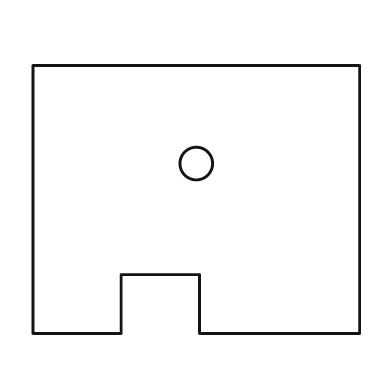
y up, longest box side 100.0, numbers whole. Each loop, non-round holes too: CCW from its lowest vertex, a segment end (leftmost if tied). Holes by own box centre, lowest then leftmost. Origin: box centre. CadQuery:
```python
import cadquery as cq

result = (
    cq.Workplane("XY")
    .moveTo(-50.0, -41.0)
    .lineTo(-23.0, -41.0)
    .lineTo(-23.0, -23.0)
    .lineTo(1.0, -23.0)
    .lineTo(1.0, -41.0)
    .lineTo(50.0, -41.0)
    .lineTo(50.0, 41.0)
    .lineTo(-50.0, 41.0)
    .close()
    .moveTo(0.0, 11.0)
    .circle(5.0)
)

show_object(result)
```